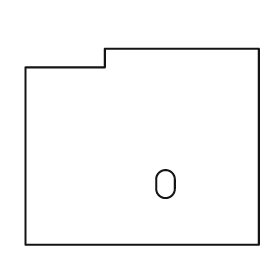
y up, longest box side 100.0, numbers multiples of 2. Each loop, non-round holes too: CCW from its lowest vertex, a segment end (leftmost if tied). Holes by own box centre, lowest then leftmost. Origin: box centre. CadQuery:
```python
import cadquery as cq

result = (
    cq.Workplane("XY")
    .moveTo(-50.0, -42.0)
    .lineTo(50.0, -42.0)
    .lineTo(50.0, 42.0)
    .lineTo(-16.0, 42.0)
    .lineTo(-16.0, 34.0)
    .lineTo(-50.0, 34.0)
    .close()
    .moveTo(6.0, -18.0)
    .threePointArc((10.0, -22.0), (14.0, -18.0))
    .lineTo(14.0, -14.0)
    .threePointArc((10.0, -10.0), (6.0, -14.0))
    .close()
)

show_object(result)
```